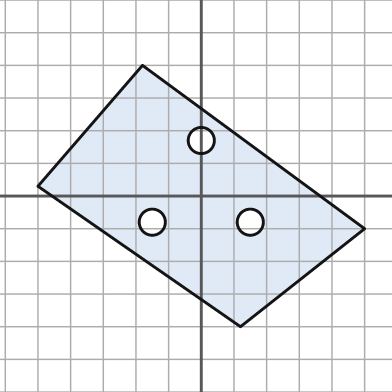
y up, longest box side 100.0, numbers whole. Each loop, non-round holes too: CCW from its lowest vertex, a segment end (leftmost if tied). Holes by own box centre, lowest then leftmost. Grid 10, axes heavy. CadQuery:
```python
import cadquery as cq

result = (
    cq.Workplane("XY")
    .moveTo(12.0, -40.0)
    .lineTo(50.0, -10.0)
    .lineTo(-18.0, 40.0)
    .lineTo(-50.0, 3.0)
    .close()
    .moveTo(-15.0, -8.0)
    .circle(4.0)
    .moveTo(15.0, -8.0)
    .circle(4.0)
    .moveTo(0.0, 17.0)
    .circle(4.0)
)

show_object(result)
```